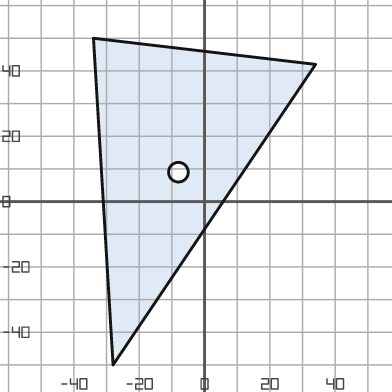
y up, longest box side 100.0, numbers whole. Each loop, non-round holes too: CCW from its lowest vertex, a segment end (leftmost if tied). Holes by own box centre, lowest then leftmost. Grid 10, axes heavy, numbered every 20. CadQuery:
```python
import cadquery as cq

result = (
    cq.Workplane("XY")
    .moveTo(-28.0, -50.0)
    .lineTo(34.0, 42.0)
    .lineTo(-34.0, 50.0)
    .close()
    .moveTo(-8.0, 9.0)
    .circle(3.0)
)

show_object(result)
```